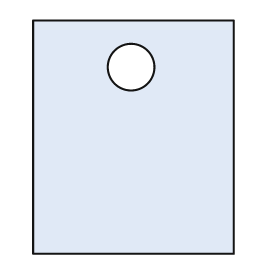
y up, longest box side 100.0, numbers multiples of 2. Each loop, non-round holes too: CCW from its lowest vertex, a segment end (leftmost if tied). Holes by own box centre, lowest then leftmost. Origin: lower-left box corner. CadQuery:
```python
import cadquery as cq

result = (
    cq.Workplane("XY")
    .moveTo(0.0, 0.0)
    .lineTo(86.0, 0.0)
    .lineTo(86.0, 100.0)
    .lineTo(0.0, 100.0)
    .close()
    .moveTo(42.0, 80.0)
    .circle(10.0)
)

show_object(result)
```